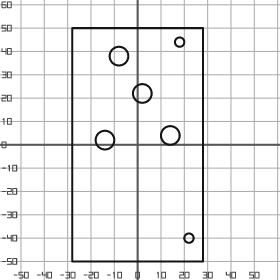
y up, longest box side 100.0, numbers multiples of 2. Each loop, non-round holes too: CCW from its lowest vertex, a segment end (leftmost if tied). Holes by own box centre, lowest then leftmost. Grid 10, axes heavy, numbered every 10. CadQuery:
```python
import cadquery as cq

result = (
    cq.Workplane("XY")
    .moveTo(-28.0, -50.0)
    .lineTo(28.0, -50.0)
    .lineTo(28.0, 50.0)
    .lineTo(-28.0, 50.0)
    .close()
    .moveTo(22.0, -40.0)
    .circle(2.0)
    .moveTo(-14.0, 2.0)
    .circle(4.0)
    .moveTo(14.0, 4.0)
    .circle(4.0)
    .moveTo(2.0, 22.0)
    .circle(4.0)
    .moveTo(-8.0, 38.0)
    .circle(4.0)
    .moveTo(18.0, 44.0)
    .circle(2.0)
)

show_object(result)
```